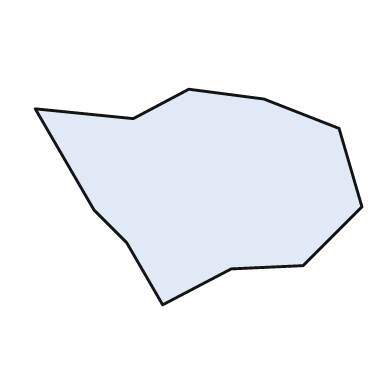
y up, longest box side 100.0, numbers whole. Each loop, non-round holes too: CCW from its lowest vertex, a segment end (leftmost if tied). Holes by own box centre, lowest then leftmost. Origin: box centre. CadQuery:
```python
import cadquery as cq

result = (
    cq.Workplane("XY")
    .moveTo(-11.0, -33.0)
    .lineTo(10.0, -22.0)
    .lineTo(32.0, -21.0)
    .lineTo(50.0, -3.0)
    .lineTo(43.0, 21.0)
    .lineTo(20.0, 30.0)
    .lineTo(-3.0, 33.0)
    .lineTo(-20.0, 24.0)
    .lineTo(-50.0, 27.0)
    .lineTo(-32.0, -4.0)
    .lineTo(-22.0, -14.0)
    .close()
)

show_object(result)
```